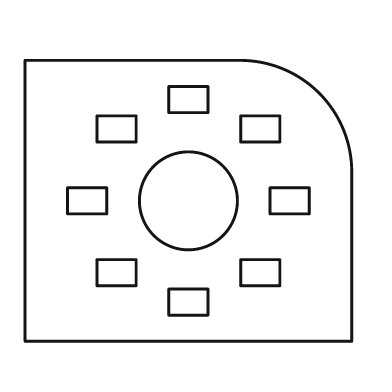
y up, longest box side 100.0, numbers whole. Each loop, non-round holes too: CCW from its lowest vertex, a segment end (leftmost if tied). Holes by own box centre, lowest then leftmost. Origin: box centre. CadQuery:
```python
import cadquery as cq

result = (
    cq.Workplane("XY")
    .moveTo(-50.0, -43.0)
    .lineTo(50.0, -43.0)
    .lineTo(50.0, 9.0)
    .threePointArc((40.0, 33.0), (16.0, 43.0))
    .lineTo(-50.0, 43.0)
    .close()
    .moveTo(-6.0, -35.0)
    .lineTo(6.0, -35.0)
    .lineTo(6.0, -27.0)
    .lineTo(-6.0, -27.0)
    .close()
    .moveTo(-28.0, -26.0)
    .lineTo(-16.0, -26.0)
    .lineTo(-16.0, -18.0)
    .lineTo(-28.0, -18.0)
    .close()
    .moveTo(16.0, -26.0)
    .lineTo(28.0, -26.0)
    .lineTo(28.0, -18.0)
    .lineTo(16.0, -18.0)
    .close()
    .moveTo(-37.0, -4.0)
    .lineTo(-25.0, -4.0)
    .lineTo(-25.0, 4.0)
    .lineTo(-37.0, 4.0)
    .close()
    .moveTo(0.0, 0.0)
    .circle(15.0)
    .moveTo(25.0, -4.0)
    .lineTo(37.0, -4.0)
    .lineTo(37.0, 4.0)
    .lineTo(25.0, 4.0)
    .close()
    .moveTo(-28.0, 18.0)
    .lineTo(-16.0, 18.0)
    .lineTo(-16.0, 26.0)
    .lineTo(-28.0, 26.0)
    .close()
    .moveTo(16.0, 18.0)
    .lineTo(28.0, 18.0)
    .lineTo(28.0, 26.0)
    .lineTo(16.0, 26.0)
    .close()
    .moveTo(-6.0, 27.0)
    .lineTo(6.0, 27.0)
    .lineTo(6.0, 35.0)
    .lineTo(-6.0, 35.0)
    .close()
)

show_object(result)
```